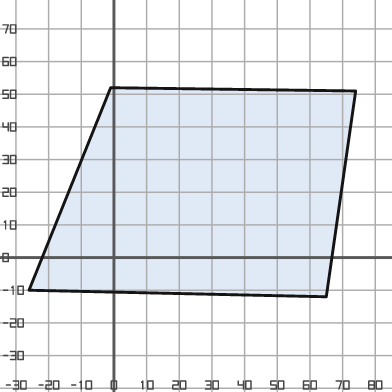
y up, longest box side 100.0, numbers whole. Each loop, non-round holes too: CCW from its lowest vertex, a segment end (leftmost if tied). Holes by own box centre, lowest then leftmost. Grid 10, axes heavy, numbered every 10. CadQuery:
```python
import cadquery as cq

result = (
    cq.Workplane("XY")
    .moveTo(65.0, -12.0)
    .lineTo(74.0, 51.0)
    .lineTo(-1.0, 52.0)
    .lineTo(-26.0, -10.0)
    .close()
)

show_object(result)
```